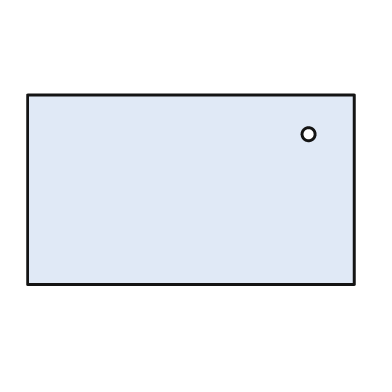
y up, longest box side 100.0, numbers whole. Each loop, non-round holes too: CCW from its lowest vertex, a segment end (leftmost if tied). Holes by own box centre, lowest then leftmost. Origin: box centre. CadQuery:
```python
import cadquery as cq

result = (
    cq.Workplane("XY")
    .moveTo(-50.0, -29.0)
    .lineTo(50.0, -29.0)
    .lineTo(50.0, 29.0)
    .lineTo(-50.0, 29.0)
    .close()
    .moveTo(36.0, 17.0)
    .circle(2.0)
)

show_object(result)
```